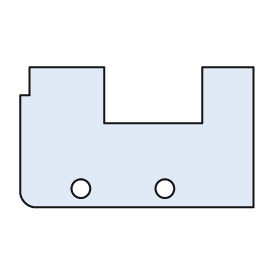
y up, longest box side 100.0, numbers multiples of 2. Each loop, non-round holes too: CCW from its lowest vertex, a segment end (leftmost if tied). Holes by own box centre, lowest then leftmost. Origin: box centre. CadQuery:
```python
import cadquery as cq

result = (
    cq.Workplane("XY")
    .moveTo(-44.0, -30.0)
    .lineTo(50.0, -30.0)
    .lineTo(50.0, 30.0)
    .lineTo(28.0, 30.0)
    .lineTo(28.0, 6.0)
    .lineTo(-14.0, 6.0)
    .lineTo(-14.0, 30.0)
    .lineTo(-46.0, 30.0)
    .lineTo(-46.0, 18.0)
    .lineTo(-50.0, 18.0)
    .lineTo(-50.0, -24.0)
    .threePointArc((-48.0, -28.0), (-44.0, -30.0))
    .close()
    .moveTo(-24.0, -22.0)
    .circle(4.0)
    .moveTo(12.0, -22.0)
    .circle(4.0)
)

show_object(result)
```